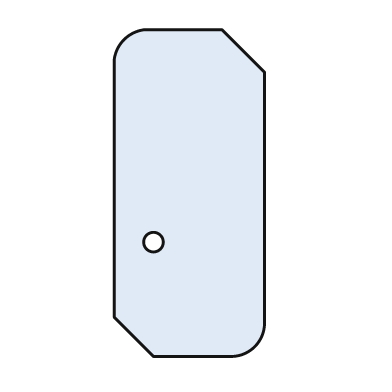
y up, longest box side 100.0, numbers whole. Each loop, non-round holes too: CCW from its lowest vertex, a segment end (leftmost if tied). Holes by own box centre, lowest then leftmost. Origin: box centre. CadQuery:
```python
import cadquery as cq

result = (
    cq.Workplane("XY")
    .moveTo(-11.0, -50.0)
    .lineTo(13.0, -50.0)
    .threePointArc((20.0, -47.0), (23.0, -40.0))
    .lineTo(23.0, 37.0)
    .lineTo(10.0, 50.0)
    .lineTo(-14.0, 50.0)
    .threePointArc((-20.0, 47.0), (-23.0, 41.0))
    .lineTo(-23.0, -38.0)
    .close()
    .moveTo(-11.0, -15.0)
    .circle(3.0)
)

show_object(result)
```